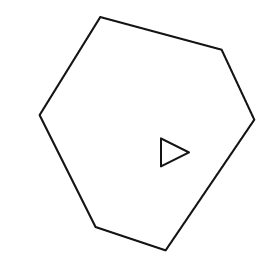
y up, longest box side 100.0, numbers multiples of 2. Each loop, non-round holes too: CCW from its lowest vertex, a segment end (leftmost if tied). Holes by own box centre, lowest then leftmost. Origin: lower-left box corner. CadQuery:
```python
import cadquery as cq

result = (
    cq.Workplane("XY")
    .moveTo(54.0, 0.0)
    .lineTo(92.0, 56.0)
    .lineTo(78.0, 86.0)
    .lineTo(26.0, 100.0)
    .lineTo(0.0, 58.0)
    .lineTo(24.0, 10.0)
    .close()
    .moveTo(52.0, 36.0)
    .lineTo(64.0, 42.0)
    .lineTo(52.0, 48.0)
    .close()
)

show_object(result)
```